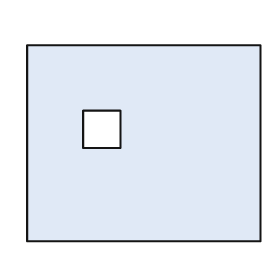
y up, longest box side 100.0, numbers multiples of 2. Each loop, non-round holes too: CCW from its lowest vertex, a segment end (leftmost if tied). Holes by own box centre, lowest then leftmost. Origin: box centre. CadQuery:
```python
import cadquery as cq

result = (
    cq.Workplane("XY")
    .moveTo(-50.0, -42.0)
    .lineTo(50.0, -42.0)
    .lineTo(50.0, 42.0)
    .lineTo(-50.0, 42.0)
    .close()
    .moveTo(-26.0, -2.0)
    .lineTo(-10.0, -2.0)
    .lineTo(-10.0, 14.0)
    .lineTo(-26.0, 14.0)
    .close()
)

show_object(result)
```